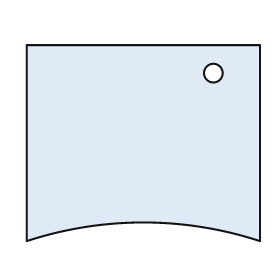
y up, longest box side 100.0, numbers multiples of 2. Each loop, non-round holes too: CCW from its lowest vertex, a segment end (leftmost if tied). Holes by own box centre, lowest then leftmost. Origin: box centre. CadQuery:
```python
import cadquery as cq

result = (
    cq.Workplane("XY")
    .moveTo(-50.0, -42.0)
    .threePointArc((0.0, -34.0), (50.0, -42.0))
    .lineTo(50.0, 42.0)
    .lineTo(-50.0, 42.0)
    .close()
    .moveTo(30.0, 30.0)
    .circle(4.0)
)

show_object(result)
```